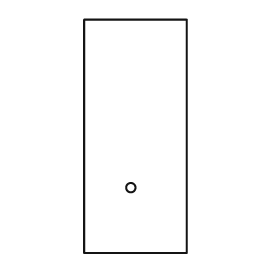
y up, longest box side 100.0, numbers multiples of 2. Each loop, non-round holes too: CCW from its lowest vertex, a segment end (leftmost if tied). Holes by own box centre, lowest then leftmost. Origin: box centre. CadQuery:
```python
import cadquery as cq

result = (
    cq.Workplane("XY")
    .moveTo(-22.0, -50.0)
    .lineTo(22.0, -50.0)
    .lineTo(22.0, 50.0)
    .lineTo(-22.0, 50.0)
    .close()
    .moveTo(-2.0, -22.0)
    .circle(2.0)
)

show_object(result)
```